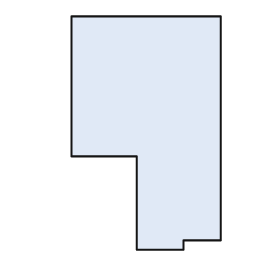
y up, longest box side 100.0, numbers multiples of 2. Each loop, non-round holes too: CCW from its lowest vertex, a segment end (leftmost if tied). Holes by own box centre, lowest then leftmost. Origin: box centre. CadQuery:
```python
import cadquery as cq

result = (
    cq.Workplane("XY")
    .moveTo(-4.0, -50.0)
    .lineTo(16.0, -50.0)
    .lineTo(16.0, -46.0)
    .lineTo(32.0, -46.0)
    .lineTo(32.0, 50.0)
    .lineTo(-32.0, 50.0)
    .lineTo(-32.0, -10.0)
    .lineTo(-4.0, -10.0)
    .close()
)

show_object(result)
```